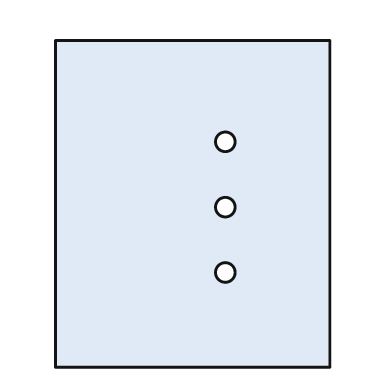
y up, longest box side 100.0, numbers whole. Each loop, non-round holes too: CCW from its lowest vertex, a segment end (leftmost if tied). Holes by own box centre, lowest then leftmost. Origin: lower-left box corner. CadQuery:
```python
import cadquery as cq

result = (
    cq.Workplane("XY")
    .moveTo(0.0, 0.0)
    .lineTo(84.0, 0.0)
    .lineTo(84.0, 100.0)
    .lineTo(0.0, 100.0)
    .close()
    .moveTo(52.0, 29.0)
    .circle(3.0)
    .moveTo(52.0, 49.0)
    .circle(3.0)
    .moveTo(52.0, 69.0)
    .circle(3.0)
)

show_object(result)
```